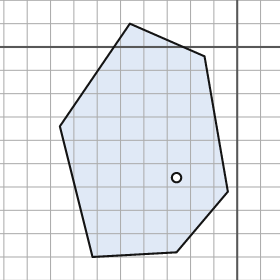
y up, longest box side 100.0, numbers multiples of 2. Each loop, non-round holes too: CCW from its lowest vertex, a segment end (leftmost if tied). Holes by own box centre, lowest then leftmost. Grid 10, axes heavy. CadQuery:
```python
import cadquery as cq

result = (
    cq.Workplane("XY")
    .moveTo(-62.0, -90.0)
    .lineTo(-26.0, -88.0)
    .lineTo(-4.0, -62.0)
    .lineTo(-14.0, -4.0)
    .lineTo(-46.0, 10.0)
    .lineTo(-76.0, -34.0)
    .close()
    .moveTo(-26.0, -56.0)
    .circle(2.0)
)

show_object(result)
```